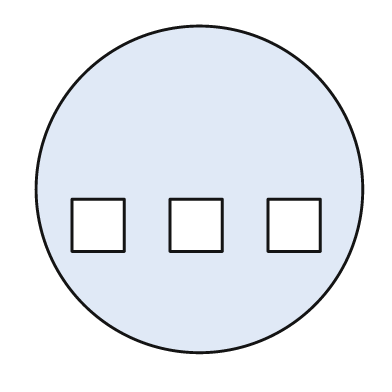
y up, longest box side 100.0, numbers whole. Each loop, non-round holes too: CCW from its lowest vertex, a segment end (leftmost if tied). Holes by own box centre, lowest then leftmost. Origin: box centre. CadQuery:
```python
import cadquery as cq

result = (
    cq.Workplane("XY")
    .moveTo(0.0, 0.0)
    .circle(50.0)
    .moveTo(-39.0, -19.0)
    .lineTo(-23.0, -19.0)
    .lineTo(-23.0, -3.0)
    .lineTo(-39.0, -3.0)
    .close()
    .moveTo(-9.0, -19.0)
    .lineTo(7.0, -19.0)
    .lineTo(7.0, -3.0)
    .lineTo(-9.0, -3.0)
    .close()
    .moveTo(21.0, -19.0)
    .lineTo(37.0, -19.0)
    .lineTo(37.0, -3.0)
    .lineTo(21.0, -3.0)
    .close()
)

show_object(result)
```